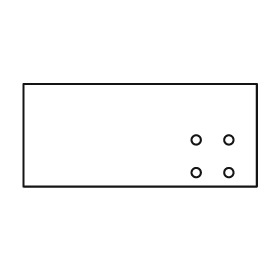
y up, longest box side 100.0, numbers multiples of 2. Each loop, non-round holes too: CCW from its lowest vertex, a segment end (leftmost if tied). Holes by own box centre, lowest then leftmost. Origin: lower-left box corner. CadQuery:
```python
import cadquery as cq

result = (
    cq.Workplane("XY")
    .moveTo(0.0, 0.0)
    .lineTo(100.0, 0.0)
    .lineTo(100.0, 44.0)
    .lineTo(0.0, 44.0)
    .close()
    .moveTo(74.0, 6.0)
    .circle(2.0)
    .moveTo(88.0, 6.0)
    .circle(2.0)
    .moveTo(74.0, 20.0)
    .circle(2.0)
    .moveTo(88.0, 20.0)
    .circle(2.0)
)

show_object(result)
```